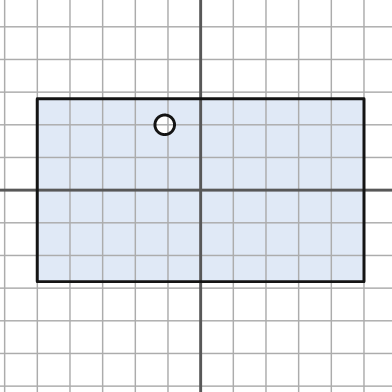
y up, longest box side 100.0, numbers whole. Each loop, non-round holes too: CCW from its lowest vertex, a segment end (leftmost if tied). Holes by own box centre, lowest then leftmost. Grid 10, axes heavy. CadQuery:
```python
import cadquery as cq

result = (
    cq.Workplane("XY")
    .moveTo(-50.0, -28.0)
    .lineTo(50.0, -28.0)
    .lineTo(50.0, 28.0)
    .lineTo(-50.0, 28.0)
    .close()
    .moveTo(-11.0, 20.0)
    .circle(3.0)
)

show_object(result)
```